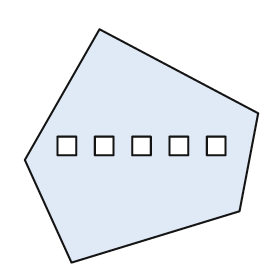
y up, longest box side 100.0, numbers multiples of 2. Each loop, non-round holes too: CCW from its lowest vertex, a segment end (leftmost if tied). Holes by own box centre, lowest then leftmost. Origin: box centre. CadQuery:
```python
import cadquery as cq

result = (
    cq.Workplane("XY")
    .moveTo(-30.0, -50.0)
    .lineTo(42.0, -28.0)
    .lineTo(50.0, 14.0)
    .lineTo(-18.0, 50.0)
    .lineTo(-50.0, -6.0)
    .close()
    .moveTo(-36.0, -4.0)
    .lineTo(-28.0, -4.0)
    .lineTo(-28.0, 4.0)
    .lineTo(-36.0, 4.0)
    .close()
    .moveTo(-20.0, -4.0)
    .lineTo(-12.0, -4.0)
    .lineTo(-12.0, 4.0)
    .lineTo(-20.0, 4.0)
    .close()
    .moveTo(-4.0, -4.0)
    .lineTo(4.0, -4.0)
    .lineTo(4.0, 4.0)
    .lineTo(-4.0, 4.0)
    .close()
    .moveTo(12.0, -4.0)
    .lineTo(20.0, -4.0)
    .lineTo(20.0, 4.0)
    .lineTo(12.0, 4.0)
    .close()
    .moveTo(28.0, -4.0)
    .lineTo(36.0, -4.0)
    .lineTo(36.0, 4.0)
    .lineTo(28.0, 4.0)
    .close()
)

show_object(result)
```